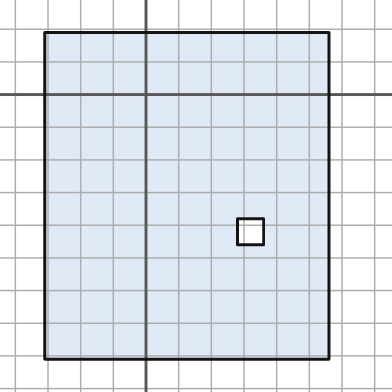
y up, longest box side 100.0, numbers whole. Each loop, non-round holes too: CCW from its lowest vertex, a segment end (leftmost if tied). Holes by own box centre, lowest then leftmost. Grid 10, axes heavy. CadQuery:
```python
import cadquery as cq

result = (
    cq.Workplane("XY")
    .moveTo(-31.0, -81.0)
    .lineTo(56.0, -81.0)
    .lineTo(56.0, 19.0)
    .lineTo(-31.0, 19.0)
    .close()
    .moveTo(28.0, -46.0)
    .lineTo(36.0, -46.0)
    .lineTo(36.0, -38.0)
    .lineTo(28.0, -38.0)
    .close()
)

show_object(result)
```